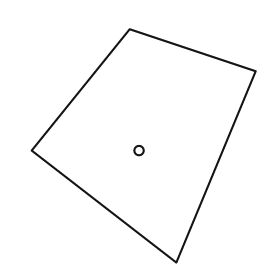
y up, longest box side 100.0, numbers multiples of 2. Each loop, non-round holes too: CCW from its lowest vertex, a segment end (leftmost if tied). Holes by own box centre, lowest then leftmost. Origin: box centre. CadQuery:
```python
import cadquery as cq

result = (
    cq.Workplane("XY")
    .moveTo(14.0, -50.0)
    .lineTo(48.0, 32.0)
    .lineTo(-6.0, 50.0)
    .lineTo(-48.0, -2.0)
    .close()
    .moveTo(-2.0, -2.0)
    .circle(2.0)
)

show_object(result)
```